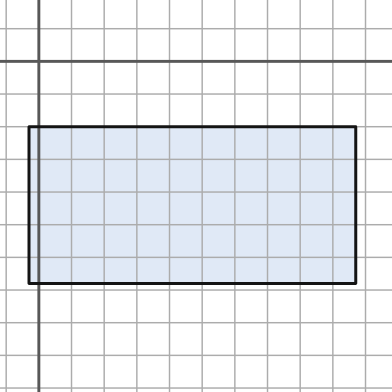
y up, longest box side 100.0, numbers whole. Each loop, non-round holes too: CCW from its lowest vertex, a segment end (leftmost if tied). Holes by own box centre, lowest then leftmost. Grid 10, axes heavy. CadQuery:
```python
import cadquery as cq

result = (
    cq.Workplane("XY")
    .moveTo(-3.0, -68.0)
    .lineTo(97.0, -68.0)
    .lineTo(97.0, -20.0)
    .lineTo(-3.0, -20.0)
    .close()
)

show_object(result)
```